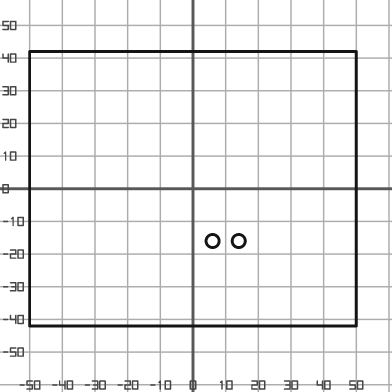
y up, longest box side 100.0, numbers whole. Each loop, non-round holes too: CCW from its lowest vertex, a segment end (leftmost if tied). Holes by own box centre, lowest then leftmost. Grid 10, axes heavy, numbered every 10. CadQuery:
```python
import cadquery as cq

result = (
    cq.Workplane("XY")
    .moveTo(-50.0, -42.0)
    .lineTo(50.0, -42.0)
    .lineTo(50.0, 42.0)
    .lineTo(-50.0, 42.0)
    .close()
    .moveTo(6.0, -16.0)
    .circle(2.0)
    .moveTo(14.0, -16.0)
    .circle(2.0)
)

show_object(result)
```